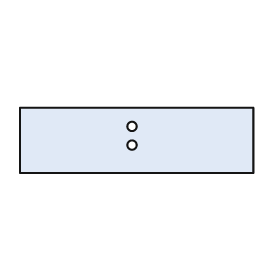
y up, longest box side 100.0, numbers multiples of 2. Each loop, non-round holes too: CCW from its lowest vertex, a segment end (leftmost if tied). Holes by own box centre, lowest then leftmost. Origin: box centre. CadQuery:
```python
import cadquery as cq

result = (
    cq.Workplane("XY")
    .moveTo(-50.0, -14.0)
    .lineTo(50.0, -14.0)
    .lineTo(50.0, 14.0)
    .lineTo(-50.0, 14.0)
    .close()
    .moveTo(-2.0, -2.0)
    .circle(2.0)
    .moveTo(-2.0, 6.0)
    .circle(2.0)
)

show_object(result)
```